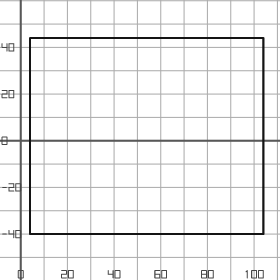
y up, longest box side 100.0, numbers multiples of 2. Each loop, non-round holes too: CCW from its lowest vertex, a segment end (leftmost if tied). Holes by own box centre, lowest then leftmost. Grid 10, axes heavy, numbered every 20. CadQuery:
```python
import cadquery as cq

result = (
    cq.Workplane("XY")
    .moveTo(4.0, -40.0)
    .lineTo(104.0, -40.0)
    .lineTo(104.0, 44.0)
    .lineTo(4.0, 44.0)
    .close()
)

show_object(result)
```